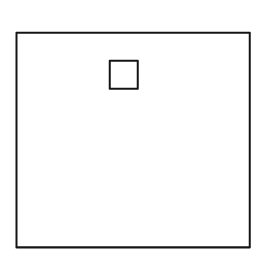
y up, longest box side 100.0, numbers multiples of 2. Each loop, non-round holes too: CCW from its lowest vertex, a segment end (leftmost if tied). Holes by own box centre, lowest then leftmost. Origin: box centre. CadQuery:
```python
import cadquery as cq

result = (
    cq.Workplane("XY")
    .moveTo(-50.0, -46.0)
    .lineTo(50.0, -46.0)
    .lineTo(50.0, 46.0)
    .lineTo(-50.0, 46.0)
    .close()
    .moveTo(-10.0, 22.0)
    .lineTo(2.0, 22.0)
    .lineTo(2.0, 34.0)
    .lineTo(-10.0, 34.0)
    .close()
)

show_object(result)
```